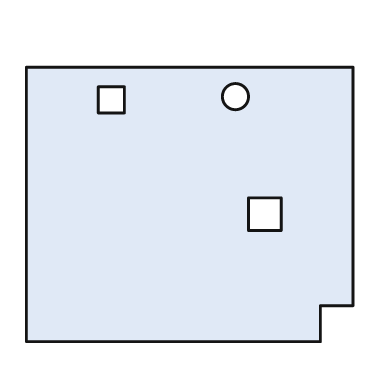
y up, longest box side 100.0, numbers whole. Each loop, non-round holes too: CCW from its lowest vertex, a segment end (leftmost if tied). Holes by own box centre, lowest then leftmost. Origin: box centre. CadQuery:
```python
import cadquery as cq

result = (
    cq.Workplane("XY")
    .moveTo(-50.0, -42.0)
    .lineTo(40.0, -42.0)
    .lineTo(40.0, -31.0)
    .lineTo(50.0, -31.0)
    .lineTo(50.0, 42.0)
    .lineTo(-50.0, 42.0)
    .close()
    .moveTo(18.0, -8.0)
    .lineTo(28.0, -8.0)
    .lineTo(28.0, 2.0)
    .lineTo(18.0, 2.0)
    .close()
    .moveTo(-28.0, 28.0)
    .lineTo(-20.0, 28.0)
    .lineTo(-20.0, 36.0)
    .lineTo(-28.0, 36.0)
    .close()
    .moveTo(14.0, 33.0)
    .circle(4.0)
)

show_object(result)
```